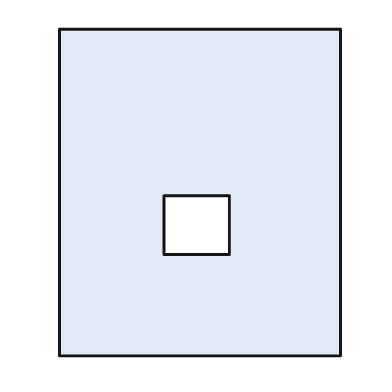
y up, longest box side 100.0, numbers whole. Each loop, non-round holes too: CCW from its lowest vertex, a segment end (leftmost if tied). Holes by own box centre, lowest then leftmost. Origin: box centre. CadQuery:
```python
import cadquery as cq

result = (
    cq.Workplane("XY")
    .moveTo(-43.0, -50.0)
    .lineTo(43.0, -50.0)
    .lineTo(43.0, 50.0)
    .lineTo(-43.0, 50.0)
    .close()
    .moveTo(-11.0, -19.0)
    .lineTo(9.0, -19.0)
    .lineTo(9.0, -1.0)
    .lineTo(-11.0, -1.0)
    .close()
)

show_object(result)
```